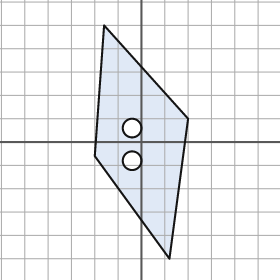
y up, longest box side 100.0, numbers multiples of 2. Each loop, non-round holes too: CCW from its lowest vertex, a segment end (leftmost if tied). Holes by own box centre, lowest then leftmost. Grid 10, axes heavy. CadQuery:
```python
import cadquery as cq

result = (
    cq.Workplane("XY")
    .moveTo(12.0, -50.0)
    .lineTo(20.0, 10.0)
    .lineTo(-16.0, 50.0)
    .lineTo(-20.0, -6.0)
    .close()
    .moveTo(-4.0, -8.0)
    .circle(4.0)
    .moveTo(-4.0, 6.0)
    .circle(4.0)
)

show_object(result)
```